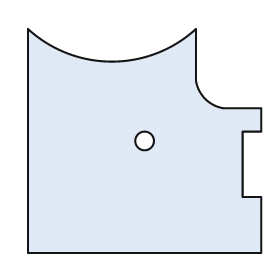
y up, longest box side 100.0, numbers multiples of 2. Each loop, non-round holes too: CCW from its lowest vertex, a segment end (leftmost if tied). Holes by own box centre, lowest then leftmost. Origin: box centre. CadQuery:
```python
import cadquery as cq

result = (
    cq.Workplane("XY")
    .moveTo(-50.0, -48.0)
    .lineTo(50.0, -48.0)
    .lineTo(50.0, -24.0)
    .lineTo(42.0, -24.0)
    .lineTo(42.0, 4.0)
    .lineTo(50.0, 4.0)
    .lineTo(50.0, 14.0)
    .lineTo(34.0, 14.0)
    .threePointArc((26.0, 18.0), (22.0, 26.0))
    .lineTo(22.0, 48.0)
    .threePointArc((-14.0, 34.0), (-50.0, 48.0))
    .close()
    .moveTo(0.0, 0.0)
    .circle(4.0)
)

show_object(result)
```